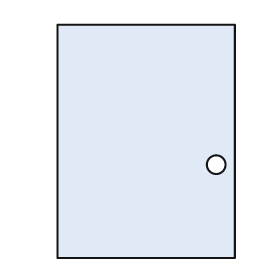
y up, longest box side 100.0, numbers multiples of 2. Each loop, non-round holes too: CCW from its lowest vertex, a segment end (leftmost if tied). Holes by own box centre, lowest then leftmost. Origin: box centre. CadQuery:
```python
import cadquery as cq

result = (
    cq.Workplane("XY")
    .moveTo(-38.0, -50.0)
    .lineTo(38.0, -50.0)
    .lineTo(38.0, 50.0)
    .lineTo(-38.0, 50.0)
    .close()
    .moveTo(30.0, -10.0)
    .circle(4.0)
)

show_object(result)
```